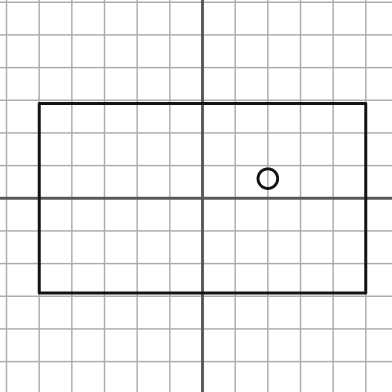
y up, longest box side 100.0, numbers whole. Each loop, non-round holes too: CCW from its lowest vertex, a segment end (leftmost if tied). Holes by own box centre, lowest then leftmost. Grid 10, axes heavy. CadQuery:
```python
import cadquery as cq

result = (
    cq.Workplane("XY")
    .moveTo(-50.0, -29.0)
    .lineTo(50.0, -29.0)
    .lineTo(50.0, 29.0)
    .lineTo(-50.0, 29.0)
    .close()
    .moveTo(20.0, 6.0)
    .circle(3.0)
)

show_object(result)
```